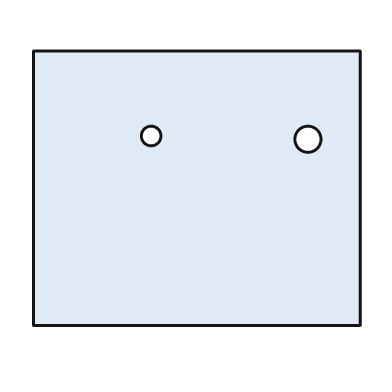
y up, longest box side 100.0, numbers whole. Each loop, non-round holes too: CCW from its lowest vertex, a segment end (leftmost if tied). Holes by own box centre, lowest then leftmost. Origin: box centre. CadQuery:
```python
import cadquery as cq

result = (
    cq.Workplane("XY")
    .moveTo(-50.0, -42.0)
    .lineTo(50.0, -42.0)
    .lineTo(50.0, 42.0)
    .lineTo(-50.0, 42.0)
    .close()
    .moveTo(34.0, 15.0)
    .circle(4.0)
    .moveTo(-14.0, 16.0)
    .circle(3.0)
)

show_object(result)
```